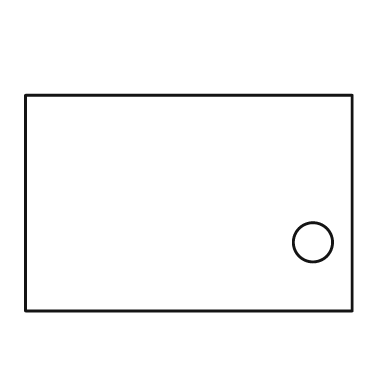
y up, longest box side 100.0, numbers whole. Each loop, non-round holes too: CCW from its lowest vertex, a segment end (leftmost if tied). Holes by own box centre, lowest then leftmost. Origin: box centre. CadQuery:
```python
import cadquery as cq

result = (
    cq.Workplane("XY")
    .moveTo(-50.0, -33.0)
    .lineTo(50.0, -33.0)
    .lineTo(50.0, 33.0)
    .lineTo(-50.0, 33.0)
    .close()
    .moveTo(38.0, -12.0)
    .circle(6.0)
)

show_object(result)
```